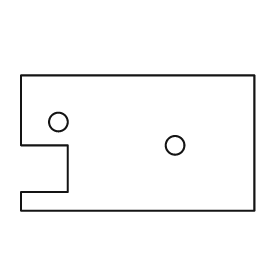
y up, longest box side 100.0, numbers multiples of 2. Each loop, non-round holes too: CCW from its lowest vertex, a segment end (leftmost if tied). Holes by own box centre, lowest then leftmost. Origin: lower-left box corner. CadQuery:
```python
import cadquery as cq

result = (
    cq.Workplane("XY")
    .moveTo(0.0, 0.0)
    .lineTo(100.0, 0.0)
    .lineTo(100.0, 58.0)
    .lineTo(0.0, 58.0)
    .lineTo(0.0, 28.0)
    .lineTo(20.0, 28.0)
    .lineTo(20.0, 8.0)
    .lineTo(0.0, 8.0)
    .close()
    .moveTo(66.0, 28.0)
    .circle(4.0)
    .moveTo(16.0, 38.0)
    .circle(4.0)
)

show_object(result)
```